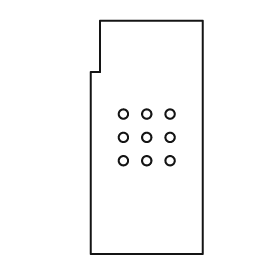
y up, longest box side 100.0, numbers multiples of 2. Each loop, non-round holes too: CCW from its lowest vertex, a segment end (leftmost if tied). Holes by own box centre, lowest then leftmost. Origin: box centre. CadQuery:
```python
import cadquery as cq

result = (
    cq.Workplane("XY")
    .moveTo(-24.0, -50.0)
    .lineTo(24.0, -50.0)
    .lineTo(24.0, 50.0)
    .lineTo(-20.0, 50.0)
    .lineTo(-20.0, 28.0)
    .lineTo(-24.0, 28.0)
    .close()
    .moveTo(-10.0, -10.0)
    .circle(2.0)
    .moveTo(0.0, -10.0)
    .circle(2.0)
    .moveTo(10.0, -10.0)
    .circle(2.0)
    .moveTo(-10.0, 0.0)
    .circle(2.0)
    .moveTo(0.0, 0.0)
    .circle(2.0)
    .moveTo(10.0, 0.0)
    .circle(2.0)
    .moveTo(-10.0, 10.0)
    .circle(2.0)
    .moveTo(0.0, 10.0)
    .circle(2.0)
    .moveTo(10.0, 10.0)
    .circle(2.0)
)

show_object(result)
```